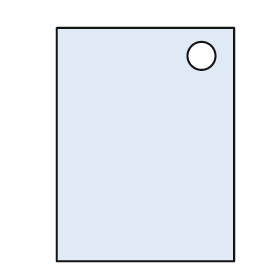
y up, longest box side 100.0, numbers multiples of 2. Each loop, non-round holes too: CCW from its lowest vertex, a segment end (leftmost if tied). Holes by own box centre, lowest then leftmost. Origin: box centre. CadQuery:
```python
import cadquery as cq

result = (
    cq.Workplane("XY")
    .moveTo(-38.0, -50.0)
    .lineTo(38.0, -50.0)
    .lineTo(38.0, 50.0)
    .lineTo(-38.0, 50.0)
    .close()
    .moveTo(24.0, 38.0)
    .circle(6.0)
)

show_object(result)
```